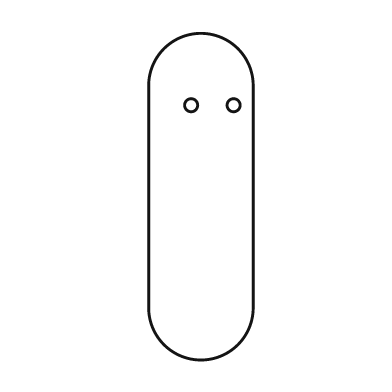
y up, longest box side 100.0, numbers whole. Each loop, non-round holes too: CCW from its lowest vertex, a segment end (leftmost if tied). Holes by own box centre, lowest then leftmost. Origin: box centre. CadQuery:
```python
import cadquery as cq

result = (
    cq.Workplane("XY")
    .moveTo(-16.0, -34.0)
    .threePointArc((0.0, -50.0), (16.0, -34.0))
    .lineTo(16.0, 34.0)
    .threePointArc((0.0, 50.0), (-16.0, 34.0))
    .close()
    .moveTo(-3.0, 28.0)
    .circle(2.0)
    .moveTo(10.0, 28.0)
    .circle(2.0)
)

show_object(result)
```